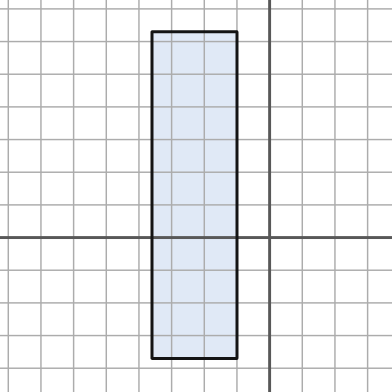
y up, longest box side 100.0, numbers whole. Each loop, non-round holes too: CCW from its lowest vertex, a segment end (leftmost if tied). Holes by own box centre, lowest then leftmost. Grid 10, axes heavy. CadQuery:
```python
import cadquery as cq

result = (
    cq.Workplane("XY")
    .moveTo(-36.0, -37.0)
    .lineTo(-10.0, -37.0)
    .lineTo(-10.0, 63.0)
    .lineTo(-36.0, 63.0)
    .close()
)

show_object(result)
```